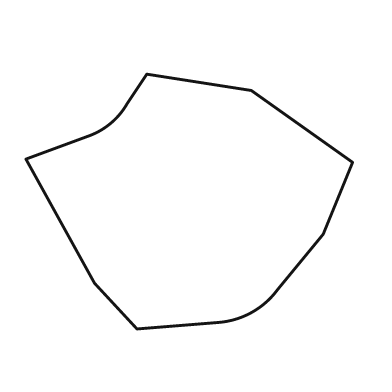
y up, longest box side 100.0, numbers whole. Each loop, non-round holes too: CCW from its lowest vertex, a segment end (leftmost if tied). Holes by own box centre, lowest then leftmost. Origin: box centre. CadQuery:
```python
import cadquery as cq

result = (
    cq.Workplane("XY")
    .moveTo(-16.0, -39.0)
    .lineTo(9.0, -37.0)
    .threePointArc((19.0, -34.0), (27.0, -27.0))
    .lineTo(41.0, -10.0)
    .lineTo(50.0, 12.0)
    .lineTo(19.0, 34.0)
    .lineTo(-13.0, 39.0)
    .lineTo(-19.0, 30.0)
    .threePointArc((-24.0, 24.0), (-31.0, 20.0))
    .lineTo(-50.0, 13.0)
    .lineTo(-29.0, -25.0)
    .close()
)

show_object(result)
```